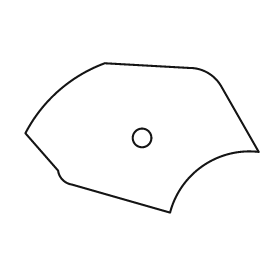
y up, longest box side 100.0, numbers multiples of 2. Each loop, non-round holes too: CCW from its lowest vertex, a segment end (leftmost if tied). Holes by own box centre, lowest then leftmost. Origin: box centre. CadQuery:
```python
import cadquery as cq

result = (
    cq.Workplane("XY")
    .moveTo(12.0, -32.0)
    .threePointArc((26.0, -12.0), (50.0, -6.0))
    .lineTo(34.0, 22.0)
    .threePointArc((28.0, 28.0), (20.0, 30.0))
    .lineTo(-16.0, 32.0)
    .threePointArc((-36.0, 20.0), (-50.0, 2.0))
    .lineTo(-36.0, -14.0)
    .threePointArc((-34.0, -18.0), (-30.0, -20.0))
    .close()
    .moveTo(0.0, 0.0)
    .circle(4.0)
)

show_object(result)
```